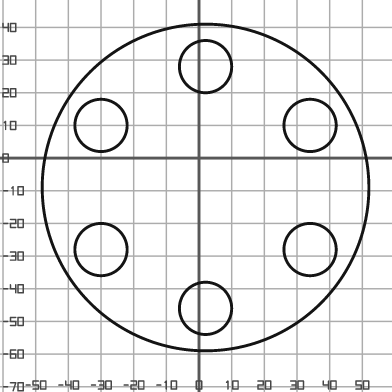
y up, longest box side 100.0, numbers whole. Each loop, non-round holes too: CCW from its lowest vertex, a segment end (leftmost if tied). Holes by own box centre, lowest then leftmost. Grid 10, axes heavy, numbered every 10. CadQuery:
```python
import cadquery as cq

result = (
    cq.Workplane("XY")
    .moveTo(2.0, -9.0)
    .circle(50.0)
    .moveTo(2.0, -46.0)
    .circle(8.0)
    .moveTo(-30.0, -28.0)
    .circle(8.0)
    .moveTo(34.0, -28.0)
    .circle(8.0)
    .moveTo(-30.0, 10.0)
    .circle(8.0)
    .moveTo(34.0, 10.0)
    .circle(8.0)
    .moveTo(2.0, 28.0)
    .circle(8.0)
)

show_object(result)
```